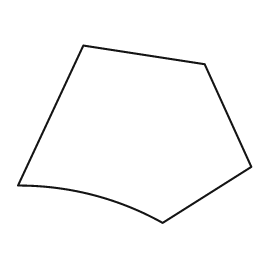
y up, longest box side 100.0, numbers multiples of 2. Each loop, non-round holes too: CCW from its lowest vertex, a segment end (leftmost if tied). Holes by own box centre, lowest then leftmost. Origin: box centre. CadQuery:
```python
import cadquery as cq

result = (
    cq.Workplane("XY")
    .moveTo(12.0, -38.0)
    .lineTo(50.0, -14.0)
    .lineTo(30.0, 30.0)
    .lineTo(-22.0, 38.0)
    .lineTo(-50.0, -22.0)
    .threePointArc((-18.0, -26.0), (12.0, -38.0))
    .close()
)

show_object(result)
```